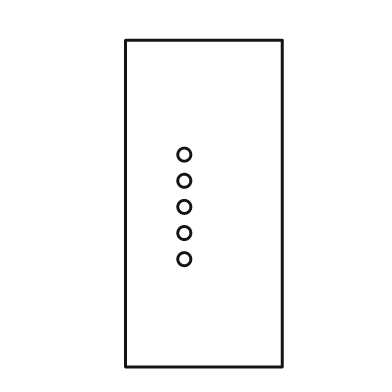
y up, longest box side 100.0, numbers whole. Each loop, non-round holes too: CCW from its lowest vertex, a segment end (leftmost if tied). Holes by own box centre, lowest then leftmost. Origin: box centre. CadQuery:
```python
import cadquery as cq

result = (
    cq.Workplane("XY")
    .moveTo(-24.0, -50.0)
    .lineTo(24.0, -50.0)
    .lineTo(24.0, 50.0)
    .lineTo(-24.0, 50.0)
    .close()
    .moveTo(-6.0, -17.0)
    .circle(2.0)
    .moveTo(-6.0, -9.0)
    .circle(2.0)
    .moveTo(-6.0, -1.0)
    .circle(2.0)
    .moveTo(-6.0, 7.0)
    .circle(2.0)
    .moveTo(-6.0, 15.0)
    .circle(2.0)
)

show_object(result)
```